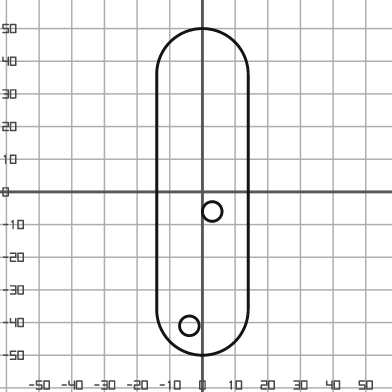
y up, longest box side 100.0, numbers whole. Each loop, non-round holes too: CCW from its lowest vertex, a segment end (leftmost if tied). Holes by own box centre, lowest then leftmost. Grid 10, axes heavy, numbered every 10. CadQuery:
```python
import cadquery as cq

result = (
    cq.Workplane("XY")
    .moveTo(-14.0, -36.0)
    .threePointArc((0.0, -50.0), (14.0, -36.0))
    .lineTo(14.0, 36.0)
    .threePointArc((0.0, 50.0), (-14.0, 36.0))
    .close()
    .moveTo(-4.0, -41.0)
    .circle(3.0)
    .moveTo(3.0, -6.0)
    .circle(3.0)
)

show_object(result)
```